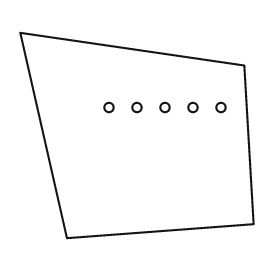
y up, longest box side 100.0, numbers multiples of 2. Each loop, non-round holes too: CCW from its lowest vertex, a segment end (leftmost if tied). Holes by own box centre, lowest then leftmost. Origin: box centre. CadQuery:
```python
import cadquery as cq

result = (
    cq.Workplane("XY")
    .moveTo(-30.0, -44.0)
    .lineTo(50.0, -38.0)
    .lineTo(46.0, 30.0)
    .lineTo(-50.0, 44.0)
    .close()
    .moveTo(-12.0, 12.0)
    .circle(2.0)
    .moveTo(0.0, 12.0)
    .circle(2.0)
    .moveTo(12.0, 12.0)
    .circle(2.0)
    .moveTo(24.0, 12.0)
    .circle(2.0)
    .moveTo(36.0, 12.0)
    .circle(2.0)
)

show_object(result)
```